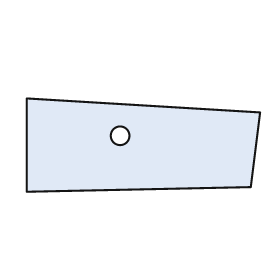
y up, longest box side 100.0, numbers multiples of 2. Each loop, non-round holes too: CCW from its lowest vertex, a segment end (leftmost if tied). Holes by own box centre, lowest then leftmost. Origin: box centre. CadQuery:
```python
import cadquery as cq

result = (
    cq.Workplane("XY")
    .moveTo(-50.0, -20.0)
    .lineTo(46.0, -18.0)
    .lineTo(50.0, 14.0)
    .lineTo(-50.0, 20.0)
    .close()
    .moveTo(-10.0, 4.0)
    .circle(4.0)
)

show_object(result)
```